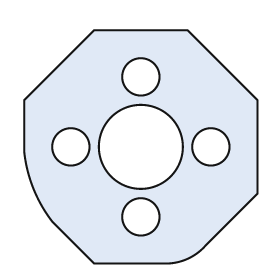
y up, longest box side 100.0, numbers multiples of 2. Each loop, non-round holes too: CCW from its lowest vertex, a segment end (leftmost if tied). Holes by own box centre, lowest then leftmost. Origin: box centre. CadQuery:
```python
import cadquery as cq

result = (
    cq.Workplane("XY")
    .moveTo(-20.0, -50.0)
    .lineTo(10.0, -50.0)
    .threePointArc((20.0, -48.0), (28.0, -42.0))
    .lineTo(50.0, -20.0)
    .lineTo(50.0, 20.0)
    .lineTo(20.0, 50.0)
    .lineTo(-20.0, 50.0)
    .lineTo(-50.0, 20.0)
    .lineTo(-50.0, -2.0)
    .threePointArc((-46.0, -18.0), (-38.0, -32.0))
    .close()
    .moveTo(0.0, -30.0)
    .circle(8.0)
    .moveTo(-30.0, 0.0)
    .circle(8.0)
    .moveTo(0.0, 0.0)
    .circle(18.0)
    .moveTo(30.0, 0.0)
    .circle(8.0)
    .moveTo(0.0, 30.0)
    .circle(8.0)
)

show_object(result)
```